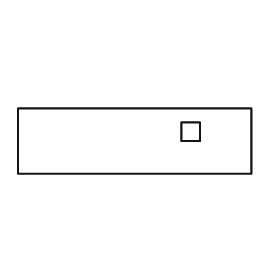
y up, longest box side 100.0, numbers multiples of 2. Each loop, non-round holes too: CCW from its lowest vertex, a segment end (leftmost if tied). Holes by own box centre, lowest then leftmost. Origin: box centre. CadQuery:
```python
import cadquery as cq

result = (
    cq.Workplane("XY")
    .moveTo(-50.0, -14.0)
    .lineTo(50.0, -14.0)
    .lineTo(50.0, 14.0)
    .lineTo(-50.0, 14.0)
    .close()
    .moveTo(20.0, 0.0)
    .lineTo(28.0, 0.0)
    .lineTo(28.0, 8.0)
    .lineTo(20.0, 8.0)
    .close()
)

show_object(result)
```